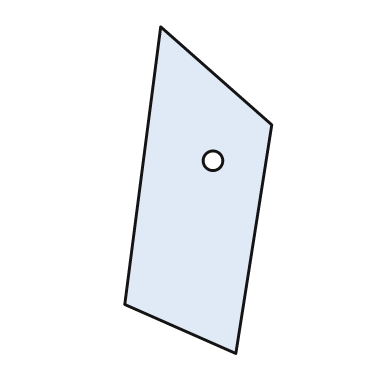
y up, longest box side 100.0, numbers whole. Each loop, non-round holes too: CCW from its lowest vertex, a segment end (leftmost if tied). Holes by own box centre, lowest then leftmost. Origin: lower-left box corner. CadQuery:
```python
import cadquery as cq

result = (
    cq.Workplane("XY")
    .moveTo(34.0, 0.0)
    .lineTo(45.0, 70.0)
    .lineTo(11.0, 100.0)
    .lineTo(0.0, 15.0)
    .close()
    .moveTo(27.0, 59.0)
    .circle(3.0)
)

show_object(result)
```